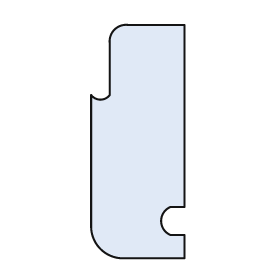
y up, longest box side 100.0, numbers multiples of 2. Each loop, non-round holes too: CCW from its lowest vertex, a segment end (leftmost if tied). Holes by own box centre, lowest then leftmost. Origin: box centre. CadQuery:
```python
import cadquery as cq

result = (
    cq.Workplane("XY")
    .moveTo(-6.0, -50.0)
    .lineTo(20.0, -50.0)
    .lineTo(20.0, -40.0)
    .lineTo(14.0, -40.0)
    .threePointArc((10.0, -34.0), (14.0, -28.0))
    .lineTo(20.0, -28.0)
    .lineTo(20.0, 50.0)
    .lineTo(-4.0, 50.0)
    .threePointArc((-10.0, 48.0), (-12.0, 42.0))
    .lineTo(-12.0, 20.0)
    .threePointArc((-16.0, 18.0), (-20.0, 20.0))
    .lineTo(-20.0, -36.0)
    .threePointArc((-16.0, -46.0), (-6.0, -50.0))
    .close()
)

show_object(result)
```